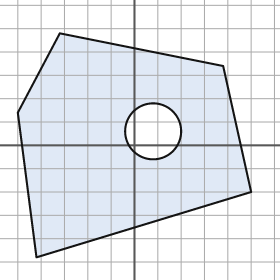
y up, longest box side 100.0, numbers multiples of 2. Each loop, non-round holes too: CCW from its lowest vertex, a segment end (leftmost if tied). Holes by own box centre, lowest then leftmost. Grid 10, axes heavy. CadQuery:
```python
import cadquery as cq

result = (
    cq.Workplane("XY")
    .moveTo(-42.0, -48.0)
    .lineTo(50.0, -20.0)
    .lineTo(38.0, 34.0)
    .lineTo(-32.0, 48.0)
    .lineTo(-50.0, 14.0)
    .close()
    .moveTo(8.0, 6.0)
    .circle(12.0)
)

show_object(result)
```